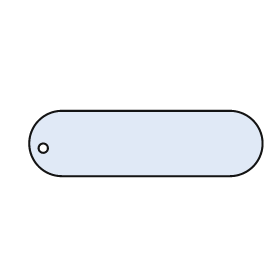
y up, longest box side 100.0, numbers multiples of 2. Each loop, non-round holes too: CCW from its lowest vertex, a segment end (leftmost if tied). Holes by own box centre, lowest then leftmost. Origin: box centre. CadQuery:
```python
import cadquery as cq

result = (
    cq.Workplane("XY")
    .moveTo(-36.0, -14.0)
    .lineTo(36.0, -14.0)
    .threePointArc((50.0, 0.0), (36.0, 14.0))
    .lineTo(-36.0, 14.0)
    .threePointArc((-50.0, 0.0), (-36.0, -14.0))
    .close()
    .moveTo(-44.0, -2.0)
    .circle(2.0)
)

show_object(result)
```